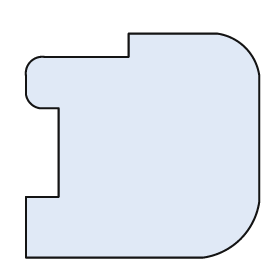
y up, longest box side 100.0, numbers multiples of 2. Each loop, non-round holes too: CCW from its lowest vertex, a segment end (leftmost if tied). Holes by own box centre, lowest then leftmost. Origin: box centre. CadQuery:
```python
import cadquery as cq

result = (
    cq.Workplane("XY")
    .moveTo(-50.0, -48.0)
    .lineTo(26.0, -48.0)
    .threePointArc((42.0, -40.0), (50.0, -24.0))
    .lineTo(50.0, 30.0)
    .threePointArc((44.0, 42.0), (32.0, 48.0))
    .lineTo(-6.0, 48.0)
    .lineTo(-6.0, 38.0)
    .lineTo(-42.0, 38.0)
    .threePointArc((-48.0, 36.0), (-50.0, 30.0))
    .lineTo(-50.0, 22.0)
    .threePointArc((-48.0, 18.0), (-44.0, 16.0))
    .lineTo(-36.0, 16.0)
    .lineTo(-36.0, -22.0)
    .lineTo(-50.0, -22.0)
    .close()
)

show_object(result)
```